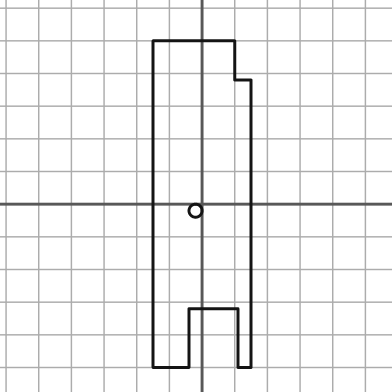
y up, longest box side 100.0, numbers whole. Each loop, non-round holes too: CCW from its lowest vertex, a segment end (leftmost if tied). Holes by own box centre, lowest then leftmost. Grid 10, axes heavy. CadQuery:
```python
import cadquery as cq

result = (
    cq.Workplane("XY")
    .moveTo(-15.0, -50.0)
    .lineTo(-4.0, -50.0)
    .lineTo(-4.0, -32.0)
    .lineTo(11.0, -32.0)
    .lineTo(11.0, -50.0)
    .lineTo(15.0, -50.0)
    .lineTo(15.0, 38.0)
    .lineTo(10.0, 38.0)
    .lineTo(10.0, 50.0)
    .lineTo(-15.0, 50.0)
    .close()
    .moveTo(-2.0, -2.0)
    .circle(2.0)
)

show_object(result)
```